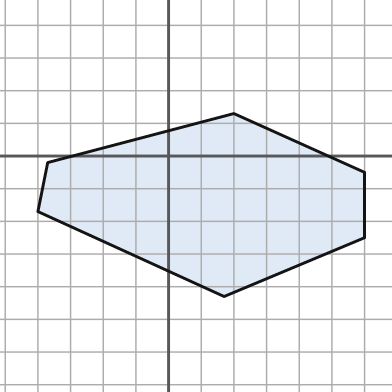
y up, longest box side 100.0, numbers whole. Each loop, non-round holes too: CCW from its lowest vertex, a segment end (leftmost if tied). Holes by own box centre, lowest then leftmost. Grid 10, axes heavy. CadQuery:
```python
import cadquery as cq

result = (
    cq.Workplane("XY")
    .moveTo(17.0, -43.0)
    .lineTo(60.0, -25.0)
    .lineTo(60.0, -5.0)
    .lineTo(20.0, 13.0)
    .lineTo(-37.0, -2.0)
    .lineTo(-40.0, -17.0)
    .close()
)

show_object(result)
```